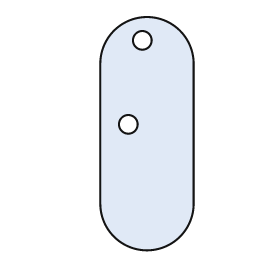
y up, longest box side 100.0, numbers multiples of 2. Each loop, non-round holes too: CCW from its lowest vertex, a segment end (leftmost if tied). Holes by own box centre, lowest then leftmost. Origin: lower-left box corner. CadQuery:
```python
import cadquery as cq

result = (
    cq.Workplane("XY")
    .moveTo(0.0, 20.0)
    .threePointArc((20.0, 0.0), (40.0, 20.0))
    .lineTo(40.0, 80.0)
    .threePointArc((20.0, 100.0), (0.0, 80.0))
    .close()
    .moveTo(12.0, 54.0)
    .circle(4.0)
    .moveTo(18.0, 90.0)
    .circle(4.0)
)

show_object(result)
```